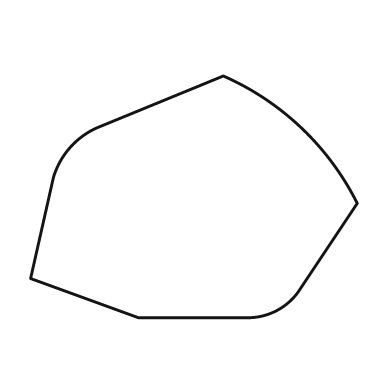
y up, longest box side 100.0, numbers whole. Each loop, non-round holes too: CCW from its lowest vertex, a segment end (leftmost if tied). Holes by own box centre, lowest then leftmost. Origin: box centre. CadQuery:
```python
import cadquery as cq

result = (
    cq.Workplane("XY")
    .moveTo(-17.0, -37.0)
    .lineTo(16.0, -37.0)
    .threePointArc((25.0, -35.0), (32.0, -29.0))
    .lineTo(50.0, -2.0)
    .threePointArc((33.0, 21.0), (9.0, 37.0))
    .lineTo(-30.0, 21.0)
    .threePointArc((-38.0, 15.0), (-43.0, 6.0))
    .lineTo(-50.0, -25.0)
    .close()
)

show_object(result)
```